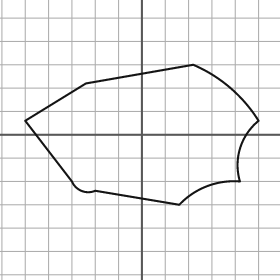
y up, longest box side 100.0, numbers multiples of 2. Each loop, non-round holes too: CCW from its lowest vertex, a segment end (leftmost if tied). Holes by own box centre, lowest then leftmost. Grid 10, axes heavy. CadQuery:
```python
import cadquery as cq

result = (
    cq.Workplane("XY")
    .moveTo(16.0, -30.0)
    .threePointArc((28.0, -22.0), (42.0, -20.0))
    .threePointArc((42.0, -6.0), (50.0, 6.0))
    .threePointArc((38.0, 20.0), (22.0, 30.0))
    .lineTo(-24.0, 22.0)
    .lineTo(-50.0, 6.0)
    .lineTo(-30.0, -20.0)
    .threePointArc((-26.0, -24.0), (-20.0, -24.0))
    .close()
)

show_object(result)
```